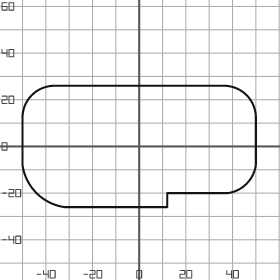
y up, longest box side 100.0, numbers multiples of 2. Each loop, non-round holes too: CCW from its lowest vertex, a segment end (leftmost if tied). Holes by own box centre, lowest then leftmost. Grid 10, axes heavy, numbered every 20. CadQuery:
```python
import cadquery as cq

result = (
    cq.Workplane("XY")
    .moveTo(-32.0, -26.0)
    .lineTo(12.0, -26.0)
    .lineTo(12.0, -20.0)
    .lineTo(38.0, -20.0)
    .threePointArc((46.0, -16.0), (50.0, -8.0))
    .lineTo(50.0, 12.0)
    .threePointArc((46.0, 22.0), (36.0, 26.0))
    .lineTo(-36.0, 26.0)
    .threePointArc((-46.0, 22.0), (-50.0, 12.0))
    .lineTo(-50.0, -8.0)
    .threePointArc((-44.0, -20.0), (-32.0, -26.0))
    .close()
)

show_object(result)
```